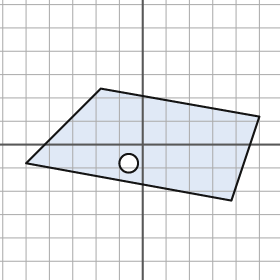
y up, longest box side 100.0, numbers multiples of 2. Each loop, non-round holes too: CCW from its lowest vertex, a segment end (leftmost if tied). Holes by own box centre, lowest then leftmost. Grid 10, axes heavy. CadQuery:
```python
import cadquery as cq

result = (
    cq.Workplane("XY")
    .moveTo(38.0, -24.0)
    .lineTo(50.0, 12.0)
    .lineTo(-18.0, 24.0)
    .lineTo(-50.0, -8.0)
    .close()
    .moveTo(-6.0, -8.0)
    .circle(4.0)
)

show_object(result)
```